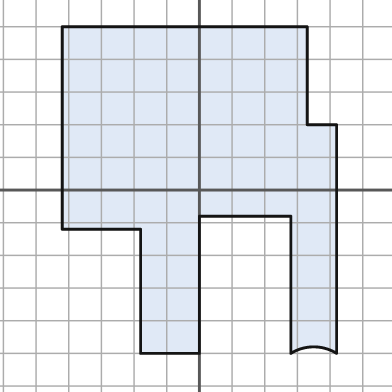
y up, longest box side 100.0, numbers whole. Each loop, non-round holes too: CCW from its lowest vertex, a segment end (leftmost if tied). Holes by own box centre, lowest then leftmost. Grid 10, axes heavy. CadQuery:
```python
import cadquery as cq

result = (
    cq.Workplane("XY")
    .moveTo(-18.0, -50.0)
    .lineTo(0.0, -50.0)
    .lineTo(0.0, -8.0)
    .lineTo(28.0, -8.0)
    .lineTo(28.0, -50.0)
    .threePointArc((35.0, -48.0), (42.0, -50.0))
    .lineTo(42.0, 20.0)
    .lineTo(33.0, 20.0)
    .lineTo(33.0, 50.0)
    .lineTo(-42.0, 50.0)
    .lineTo(-42.0, -12.0)
    .lineTo(-18.0, -12.0)
    .close()
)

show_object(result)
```